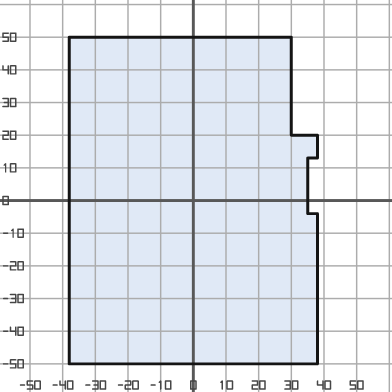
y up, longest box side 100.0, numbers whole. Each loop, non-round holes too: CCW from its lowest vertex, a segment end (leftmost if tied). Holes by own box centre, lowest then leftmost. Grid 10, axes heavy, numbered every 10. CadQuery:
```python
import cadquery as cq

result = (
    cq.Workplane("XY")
    .moveTo(-38.0, -50.0)
    .lineTo(38.0, -50.0)
    .lineTo(38.0, -4.0)
    .lineTo(35.0, -4.0)
    .lineTo(35.0, 13.0)
    .lineTo(38.0, 13.0)
    .lineTo(38.0, 20.0)
    .lineTo(30.0, 20.0)
    .lineTo(30.0, 50.0)
    .lineTo(-38.0, 50.0)
    .close()
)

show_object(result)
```